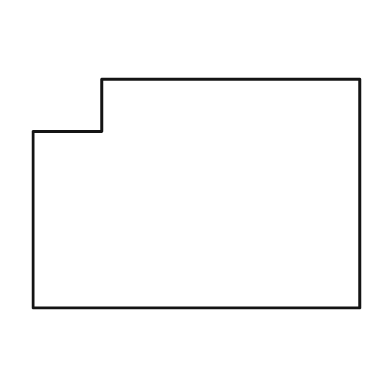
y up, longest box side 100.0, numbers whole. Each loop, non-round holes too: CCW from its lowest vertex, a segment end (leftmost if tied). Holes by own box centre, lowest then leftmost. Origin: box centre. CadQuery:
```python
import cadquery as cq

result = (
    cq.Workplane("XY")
    .moveTo(-50.0, -35.0)
    .lineTo(50.0, -35.0)
    .lineTo(50.0, 35.0)
    .lineTo(-29.0, 35.0)
    .lineTo(-29.0, 19.0)
    .lineTo(-50.0, 19.0)
    .close()
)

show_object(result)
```